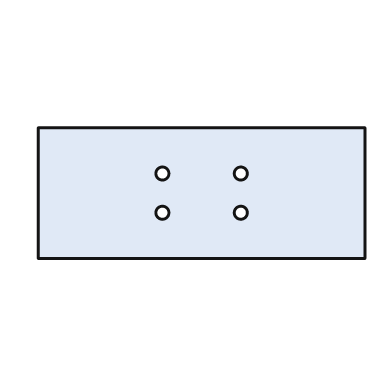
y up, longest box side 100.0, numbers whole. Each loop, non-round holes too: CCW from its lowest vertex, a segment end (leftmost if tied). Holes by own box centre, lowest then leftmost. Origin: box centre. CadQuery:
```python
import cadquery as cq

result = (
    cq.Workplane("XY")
    .moveTo(-50.0, -20.0)
    .lineTo(50.0, -20.0)
    .lineTo(50.0, 20.0)
    .lineTo(-50.0, 20.0)
    .close()
    .moveTo(-12.0, -6.0)
    .circle(2.0)
    .moveTo(12.0, -6.0)
    .circle(2.0)
    .moveTo(-12.0, 6.0)
    .circle(2.0)
    .moveTo(12.0, 6.0)
    .circle(2.0)
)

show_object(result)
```